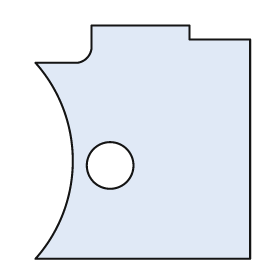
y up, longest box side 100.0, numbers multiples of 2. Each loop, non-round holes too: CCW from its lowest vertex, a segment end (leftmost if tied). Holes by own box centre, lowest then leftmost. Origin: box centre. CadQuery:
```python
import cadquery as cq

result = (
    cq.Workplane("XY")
    .moveTo(-46.0, -50.0)
    .lineTo(46.0, -50.0)
    .lineTo(46.0, 44.0)
    .lineTo(20.0, 44.0)
    .lineTo(20.0, 50.0)
    .lineTo(-22.0, 50.0)
    .lineTo(-22.0, 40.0)
    .threePointArc((-24.0, 36.0), (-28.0, 34.0))
    .lineTo(-46.0, 34.0)
    .threePointArc((-30.0, -8.0), (-46.0, -50.0))
    .close()
    .moveTo(-14.0, -10.0)
    .circle(10.0)
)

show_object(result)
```